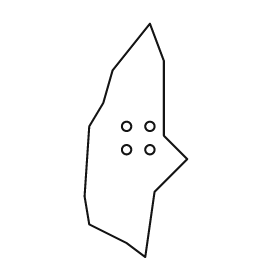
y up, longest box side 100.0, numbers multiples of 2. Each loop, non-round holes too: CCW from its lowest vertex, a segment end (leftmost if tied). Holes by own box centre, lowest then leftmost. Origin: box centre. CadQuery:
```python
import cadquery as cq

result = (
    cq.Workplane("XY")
    .moveTo(4.0, -50.0)
    .lineTo(8.0, -22.0)
    .lineTo(22.0, -8.0)
    .lineTo(12.0, 2.0)
    .lineTo(12.0, 34.0)
    .lineTo(6.0, 50.0)
    .lineTo(-10.0, 30.0)
    .lineTo(-14.0, 16.0)
    .lineTo(-20.0, 6.0)
    .lineTo(-22.0, -24.0)
    .lineTo(-20.0, -36.0)
    .lineTo(-4.0, -44.0)
    .close()
    .moveTo(-4.0, -4.0)
    .circle(2.0)
    .moveTo(6.0, -4.0)
    .circle(2.0)
    .moveTo(-4.0, 6.0)
    .circle(2.0)
    .moveTo(6.0, 6.0)
    .circle(2.0)
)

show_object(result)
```